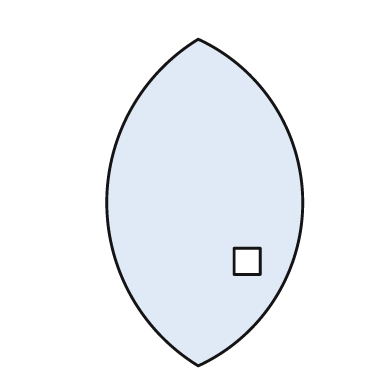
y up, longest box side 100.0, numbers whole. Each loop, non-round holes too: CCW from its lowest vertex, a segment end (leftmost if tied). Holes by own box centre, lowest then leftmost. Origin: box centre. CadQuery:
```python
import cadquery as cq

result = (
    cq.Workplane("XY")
    .moveTo(-2.0, -50.0)
    .threePointArc((30.0, 0.0), (-2.0, 50.0))
    .threePointArc((-30.0, 0.0), (-2.0, -50.0))
    .close()
    .moveTo(9.0, -22.0)
    .lineTo(17.0, -22.0)
    .lineTo(17.0, -14.0)
    .lineTo(9.0, -14.0)
    .close()
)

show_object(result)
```